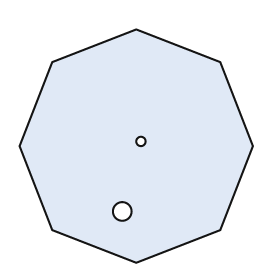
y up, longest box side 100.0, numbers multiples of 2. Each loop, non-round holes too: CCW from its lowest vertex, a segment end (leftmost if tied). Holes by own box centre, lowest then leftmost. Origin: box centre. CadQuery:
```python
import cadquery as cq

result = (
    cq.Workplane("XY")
    .moveTo(0.0, -50.0)
    .lineTo(36.0, -36.0)
    .lineTo(50.0, 0.0)
    .lineTo(36.0, 36.0)
    .lineTo(0.0, 50.0)
    .lineTo(-36.0, 36.0)
    .lineTo(-50.0, 0.0)
    .lineTo(-36.0, -36.0)
    .close()
    .moveTo(-6.0, -28.0)
    .circle(4.0)
    .moveTo(2.0, 2.0)
    .circle(2.0)
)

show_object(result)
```